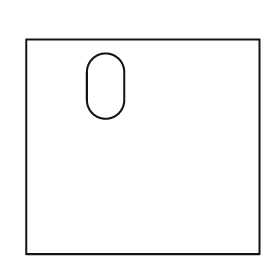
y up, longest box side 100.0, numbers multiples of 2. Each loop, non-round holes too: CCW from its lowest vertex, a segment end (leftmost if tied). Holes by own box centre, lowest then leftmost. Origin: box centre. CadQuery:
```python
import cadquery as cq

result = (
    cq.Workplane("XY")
    .moveTo(-50.0, -46.0)
    .lineTo(50.0, -46.0)
    .lineTo(50.0, 46.0)
    .lineTo(-50.0, 46.0)
    .close()
    .moveTo(-24.0, 20.0)
    .threePointArc((-16.0, 12.0), (-8.0, 20.0))
    .lineTo(-8.0, 32.0)
    .threePointArc((-16.0, 40.0), (-24.0, 32.0))
    .close()
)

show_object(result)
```